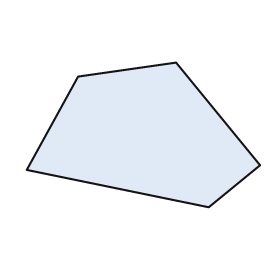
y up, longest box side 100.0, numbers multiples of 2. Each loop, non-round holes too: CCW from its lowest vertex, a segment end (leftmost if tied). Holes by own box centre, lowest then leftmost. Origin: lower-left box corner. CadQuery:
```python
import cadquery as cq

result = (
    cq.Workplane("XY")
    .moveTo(78.0, 0.0)
    .lineTo(100.0, 18.0)
    .lineTo(64.0, 62.0)
    .lineTo(22.0, 56.0)
    .lineTo(0.0, 16.0)
    .close()
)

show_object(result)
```